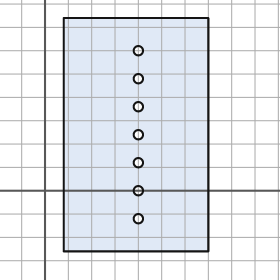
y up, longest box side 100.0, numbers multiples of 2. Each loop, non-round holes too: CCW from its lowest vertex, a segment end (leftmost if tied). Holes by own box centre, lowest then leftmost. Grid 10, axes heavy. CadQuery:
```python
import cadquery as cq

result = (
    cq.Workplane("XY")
    .moveTo(8.0, -26.0)
    .lineTo(70.0, -26.0)
    .lineTo(70.0, 74.0)
    .lineTo(8.0, 74.0)
    .close()
    .moveTo(40.0, -12.0)
    .circle(2.0)
    .moveTo(40.0, 0.0)
    .circle(2.0)
    .moveTo(40.0, 12.0)
    .circle(2.0)
    .moveTo(40.0, 24.0)
    .circle(2.0)
    .moveTo(40.0, 36.0)
    .circle(2.0)
    .moveTo(40.0, 48.0)
    .circle(2.0)
    .moveTo(40.0, 60.0)
    .circle(2.0)
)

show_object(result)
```